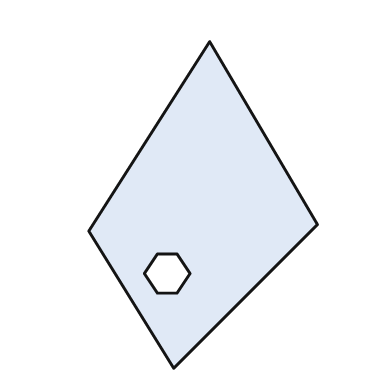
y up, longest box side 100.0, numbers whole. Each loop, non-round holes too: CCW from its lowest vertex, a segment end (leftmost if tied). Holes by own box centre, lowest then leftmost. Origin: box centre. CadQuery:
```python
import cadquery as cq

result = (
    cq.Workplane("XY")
    .moveTo(-9.0, -50.0)
    .lineTo(35.0, -6.0)
    .lineTo(2.0, 50.0)
    .lineTo(-35.0, -8.0)
    .close()
    .moveTo(-14.0, -27.0)
    .lineTo(-8.0, -27.0)
    .lineTo(-4.0, -21.0)
    .lineTo(-8.0, -15.0)
    .lineTo(-14.0, -15.0)
    .lineTo(-18.0, -21.0)
    .close()
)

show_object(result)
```